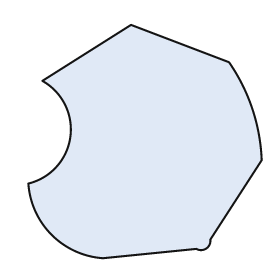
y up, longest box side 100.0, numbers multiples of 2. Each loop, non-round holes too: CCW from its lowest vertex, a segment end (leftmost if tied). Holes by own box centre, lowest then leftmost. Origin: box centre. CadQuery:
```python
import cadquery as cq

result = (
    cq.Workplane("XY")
    .moveTo(-18.0, -50.0)
    .lineTo(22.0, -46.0)
    .threePointArc((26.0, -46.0), (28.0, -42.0))
    .lineTo(50.0, -8.0)
    .threePointArc((46.0, 14.0), (36.0, 34.0))
    .lineTo(-6.0, 50.0)
    .lineTo(-44.0, 26.0)
    .threePointArc((-32.0, 2.0), (-50.0, -18.0))
    .threePointArc((-40.0, -40.0), (-18.0, -50.0))
    .close()
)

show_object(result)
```